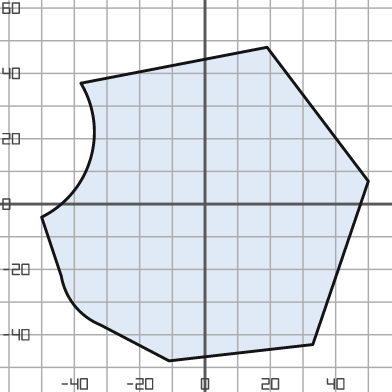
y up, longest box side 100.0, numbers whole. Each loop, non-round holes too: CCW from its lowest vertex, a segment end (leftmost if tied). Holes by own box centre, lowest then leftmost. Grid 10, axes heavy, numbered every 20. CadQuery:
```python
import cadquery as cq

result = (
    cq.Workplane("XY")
    .moveTo(-11.0, -48.0)
    .lineTo(33.0, -43.0)
    .lineTo(50.0, 7.0)
    .lineTo(19.0, 48.0)
    .lineTo(-38.0, 37.0)
    .threePointArc((-35.0, 14.0), (-50.0, -4.0))
    .lineTo(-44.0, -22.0)
    .threePointArc((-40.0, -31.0), (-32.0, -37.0))
    .close()
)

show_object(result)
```